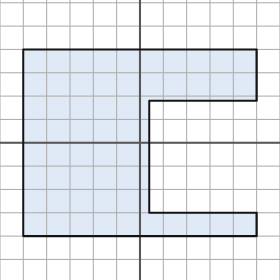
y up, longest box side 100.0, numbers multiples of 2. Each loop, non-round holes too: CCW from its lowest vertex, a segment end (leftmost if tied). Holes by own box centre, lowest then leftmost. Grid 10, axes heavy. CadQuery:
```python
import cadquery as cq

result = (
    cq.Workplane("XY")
    .moveTo(-50.0, -40.0)
    .lineTo(50.0, -40.0)
    .lineTo(50.0, -30.0)
    .lineTo(4.0, -30.0)
    .lineTo(4.0, 18.0)
    .lineTo(50.0, 18.0)
    .lineTo(50.0, 40.0)
    .lineTo(-50.0, 40.0)
    .close()
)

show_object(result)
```